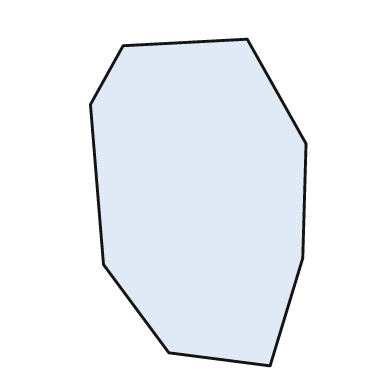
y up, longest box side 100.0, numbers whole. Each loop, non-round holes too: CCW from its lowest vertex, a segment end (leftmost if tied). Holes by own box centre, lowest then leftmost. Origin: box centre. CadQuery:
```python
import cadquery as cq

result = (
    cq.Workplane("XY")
    .moveTo(22.0, -50.0)
    .lineTo(32.0, -17.0)
    .lineTo(33.0, 18.0)
    .lineTo(15.0, 50.0)
    .lineTo(-23.0, 48.0)
    .lineTo(-33.0, 30.0)
    .lineTo(-29.0, -19.0)
    .lineTo(-9.0, -46.0)
    .close()
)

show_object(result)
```